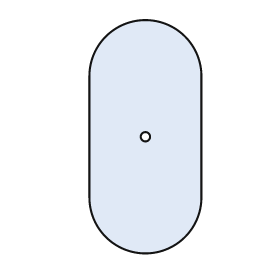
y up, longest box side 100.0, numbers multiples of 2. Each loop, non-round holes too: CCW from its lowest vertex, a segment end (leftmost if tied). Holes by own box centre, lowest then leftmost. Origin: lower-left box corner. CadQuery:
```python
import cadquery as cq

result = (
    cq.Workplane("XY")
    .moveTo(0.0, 24.0)
    .threePointArc((24.0, 0.0), (48.0, 24.0))
    .lineTo(48.0, 76.0)
    .threePointArc((24.0, 100.0), (0.0, 76.0))
    .close()
    .moveTo(24.0, 50.0)
    .circle(2.0)
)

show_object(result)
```